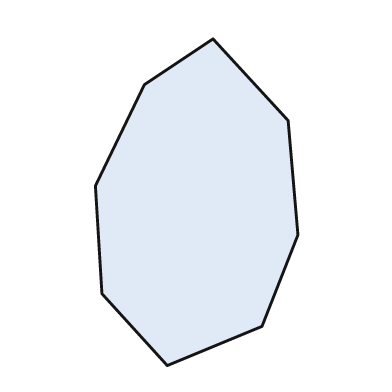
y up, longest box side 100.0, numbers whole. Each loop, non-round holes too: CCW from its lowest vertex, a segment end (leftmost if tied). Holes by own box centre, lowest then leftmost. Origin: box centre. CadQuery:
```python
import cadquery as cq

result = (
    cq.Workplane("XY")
    .moveTo(-9.0, -50.0)
    .lineTo(20.0, -38.0)
    .lineTo(31.0, -10.0)
    .lineTo(28.0, 25.0)
    .lineTo(5.0, 50.0)
    .lineTo(-16.0, 36.0)
    .lineTo(-31.0, 5.0)
    .lineTo(-29.0, -28.0)
    .close()
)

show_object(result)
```